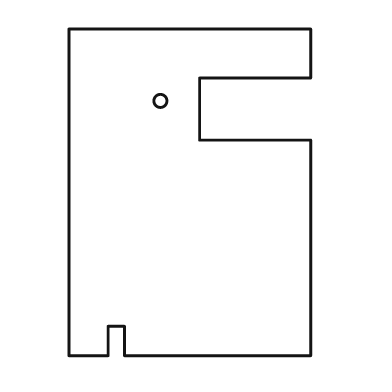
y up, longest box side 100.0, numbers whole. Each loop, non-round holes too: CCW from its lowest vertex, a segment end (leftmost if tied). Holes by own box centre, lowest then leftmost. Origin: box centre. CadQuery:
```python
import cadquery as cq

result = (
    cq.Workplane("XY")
    .moveTo(-37.0, -50.0)
    .lineTo(-25.0, -50.0)
    .lineTo(-25.0, -41.0)
    .lineTo(-20.0, -41.0)
    .lineTo(-20.0, -50.0)
    .lineTo(37.0, -50.0)
    .lineTo(37.0, 16.0)
    .lineTo(3.0, 16.0)
    .lineTo(3.0, 35.0)
    .lineTo(37.0, 35.0)
    .lineTo(37.0, 50.0)
    .lineTo(-37.0, 50.0)
    .close()
    .moveTo(-9.0, 28.0)
    .circle(2.0)
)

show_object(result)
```